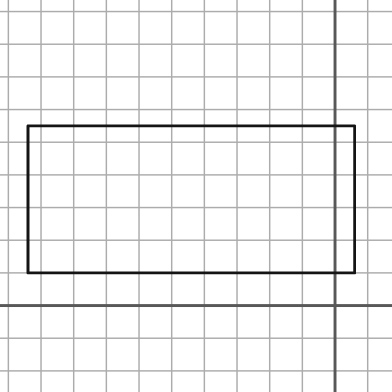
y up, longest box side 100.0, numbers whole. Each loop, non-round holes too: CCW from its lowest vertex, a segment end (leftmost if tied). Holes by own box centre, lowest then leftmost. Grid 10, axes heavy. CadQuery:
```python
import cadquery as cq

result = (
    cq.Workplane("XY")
    .moveTo(-94.0, 10.0)
    .lineTo(6.0, 10.0)
    .lineTo(6.0, 55.0)
    .lineTo(-94.0, 55.0)
    .close()
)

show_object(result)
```